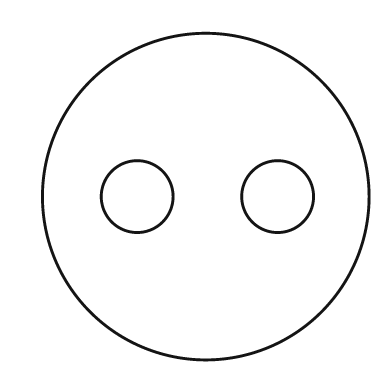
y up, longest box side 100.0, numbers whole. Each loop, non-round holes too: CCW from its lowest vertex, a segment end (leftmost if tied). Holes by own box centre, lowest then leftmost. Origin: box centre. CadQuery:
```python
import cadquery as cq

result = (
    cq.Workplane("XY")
    .moveTo(0.0, 0.0)
    .circle(50.0)
    .moveTo(-21.0, 0.0)
    .circle(11.0)
    .moveTo(22.0, 0.0)
    .circle(11.0)
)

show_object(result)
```